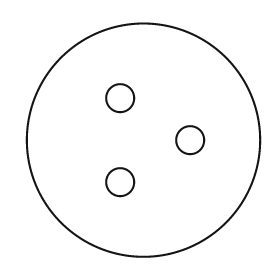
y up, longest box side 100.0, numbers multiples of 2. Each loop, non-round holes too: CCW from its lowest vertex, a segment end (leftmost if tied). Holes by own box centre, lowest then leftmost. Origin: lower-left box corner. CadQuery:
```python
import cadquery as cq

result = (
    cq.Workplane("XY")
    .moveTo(50.0, 50.0)
    .circle(50.0)
    .moveTo(40.0, 32.0)
    .circle(6.0)
    .moveTo(70.0, 50.0)
    .circle(6.0)
    .moveTo(40.0, 68.0)
    .circle(6.0)
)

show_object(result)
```